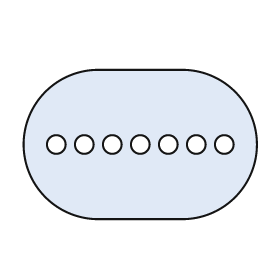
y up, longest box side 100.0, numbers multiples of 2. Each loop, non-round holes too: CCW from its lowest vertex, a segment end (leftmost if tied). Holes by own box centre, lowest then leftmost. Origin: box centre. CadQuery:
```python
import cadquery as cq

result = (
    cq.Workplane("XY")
    .moveTo(-18.0, -32.0)
    .lineTo(18.0, -32.0)
    .threePointArc((50.0, 0.0), (18.0, 32.0))
    .lineTo(-18.0, 32.0)
    .threePointArc((-50.0, 0.0), (-18.0, -32.0))
    .close()
    .moveTo(-36.0, 0.0)
    .circle(4.0)
    .moveTo(-24.0, 0.0)
    .circle(4.0)
    .moveTo(-12.0, 0.0)
    .circle(4.0)
    .moveTo(0.0, 0.0)
    .circle(4.0)
    .moveTo(12.0, 0.0)
    .circle(4.0)
    .moveTo(24.0, 0.0)
    .circle(4.0)
    .moveTo(36.0, 0.0)
    .circle(4.0)
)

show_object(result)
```